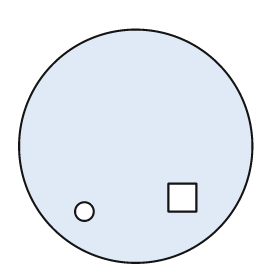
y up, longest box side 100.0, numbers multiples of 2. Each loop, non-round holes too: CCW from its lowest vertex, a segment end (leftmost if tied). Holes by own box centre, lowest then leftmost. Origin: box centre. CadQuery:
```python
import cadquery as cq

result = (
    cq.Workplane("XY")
    .moveTo(0.0, 0.0)
    .circle(50.0)
    .moveTo(-22.0, -28.0)
    .circle(4.0)
    .moveTo(14.0, -28.0)
    .lineTo(26.0, -28.0)
    .lineTo(26.0, -16.0)
    .lineTo(14.0, -16.0)
    .close()
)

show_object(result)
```